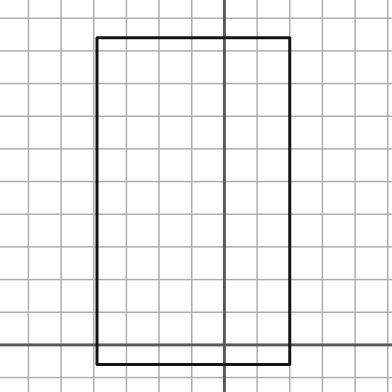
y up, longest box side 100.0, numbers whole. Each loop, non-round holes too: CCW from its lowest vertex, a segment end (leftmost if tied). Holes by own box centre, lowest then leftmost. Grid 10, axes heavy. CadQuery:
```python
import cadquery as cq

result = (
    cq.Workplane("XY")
    .moveTo(-39.0, -6.0)
    .lineTo(20.0, -6.0)
    .lineTo(20.0, 94.0)
    .lineTo(-39.0, 94.0)
    .close()
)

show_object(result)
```